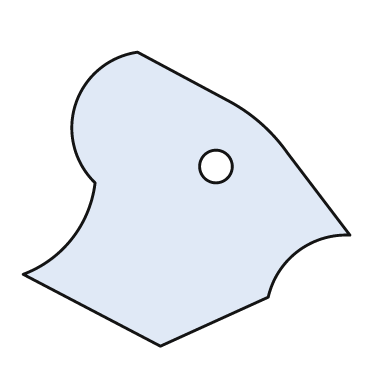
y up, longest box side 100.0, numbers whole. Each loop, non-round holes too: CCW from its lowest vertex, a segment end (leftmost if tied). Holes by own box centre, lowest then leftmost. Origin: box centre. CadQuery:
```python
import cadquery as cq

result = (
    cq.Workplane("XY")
    .moveTo(-8.0, -45.0)
    .lineTo(25.0, -30.0)
    .threePointArc((34.0, -16.0), (50.0, -11.0))
    .lineTo(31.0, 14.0)
    .threePointArc((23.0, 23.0), (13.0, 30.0))
    .lineTo(-15.0, 45.0)
    .threePointArc((-34.0, 29.0), (-28.0, 5.0))
    .threePointArc((-35.0, -12.0), (-50.0, -23.0))
    .close()
    .moveTo(9.0, 10.0)
    .circle(5.0)
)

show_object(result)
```